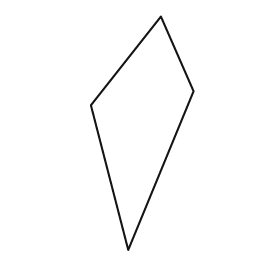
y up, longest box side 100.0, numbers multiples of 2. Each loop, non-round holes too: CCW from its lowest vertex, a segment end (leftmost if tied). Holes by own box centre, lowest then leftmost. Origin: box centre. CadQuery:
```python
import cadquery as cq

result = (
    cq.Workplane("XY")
    .moveTo(-6.0, -50.0)
    .lineTo(22.0, 18.0)
    .lineTo(8.0, 50.0)
    .lineTo(-22.0, 12.0)
    .close()
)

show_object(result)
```